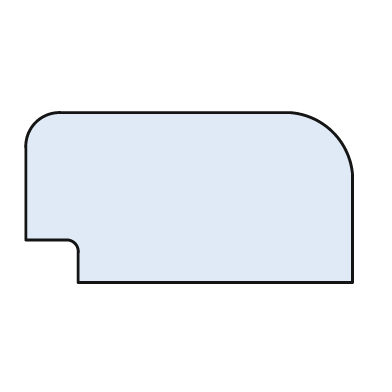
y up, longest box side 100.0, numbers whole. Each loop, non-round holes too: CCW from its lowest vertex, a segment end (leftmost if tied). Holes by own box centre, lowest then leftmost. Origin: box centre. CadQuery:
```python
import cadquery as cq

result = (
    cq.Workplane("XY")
    .moveTo(-34.0, -26.0)
    .lineTo(50.0, -26.0)
    .lineTo(50.0, 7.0)
    .threePointArc((44.0, 20.0), (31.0, 26.0))
    .lineTo(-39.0, 26.0)
    .threePointArc((-47.0, 23.0), (-50.0, 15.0))
    .lineTo(-50.0, -13.0)
    .lineTo(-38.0, -13.0)
    .threePointArc((-35.0, -14.0), (-34.0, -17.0))
    .close()
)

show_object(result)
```